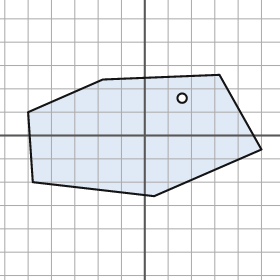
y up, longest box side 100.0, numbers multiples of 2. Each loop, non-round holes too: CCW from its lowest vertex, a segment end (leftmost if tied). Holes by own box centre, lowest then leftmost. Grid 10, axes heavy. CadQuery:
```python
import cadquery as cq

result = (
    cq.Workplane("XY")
    .moveTo(4.0, -26.0)
    .lineTo(50.0, -6.0)
    .lineTo(32.0, 26.0)
    .lineTo(-18.0, 24.0)
    .lineTo(-50.0, 10.0)
    .lineTo(-48.0, -20.0)
    .close()
    .moveTo(16.0, 16.0)
    .circle(2.0)
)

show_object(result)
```